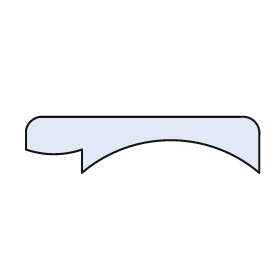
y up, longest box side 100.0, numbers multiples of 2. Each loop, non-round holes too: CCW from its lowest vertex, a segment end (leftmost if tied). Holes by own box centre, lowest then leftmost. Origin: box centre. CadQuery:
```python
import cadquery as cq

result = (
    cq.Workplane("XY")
    .moveTo(-26.0, -12.0)
    .threePointArc((12.0, 2.0), (50.0, -12.0))
    .lineTo(50.0, 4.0)
    .threePointArc((48.0, 10.0), (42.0, 12.0))
    .lineTo(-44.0, 12.0)
    .threePointArc((-48.0, 10.0), (-50.0, 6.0))
    .lineTo(-50.0, -2.0)
    .threePointArc((-38.0, -4.0), (-26.0, -2.0))
    .close()
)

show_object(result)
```